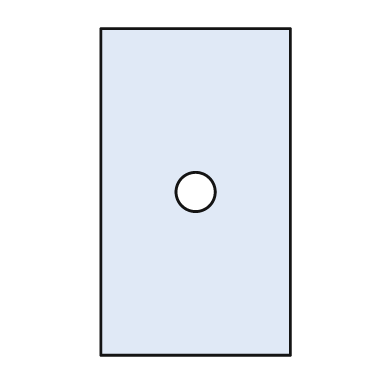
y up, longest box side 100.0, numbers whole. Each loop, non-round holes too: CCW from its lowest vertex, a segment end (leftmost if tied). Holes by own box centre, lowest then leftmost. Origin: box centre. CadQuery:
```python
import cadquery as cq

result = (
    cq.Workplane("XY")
    .moveTo(-29.0, -50.0)
    .lineTo(29.0, -50.0)
    .lineTo(29.0, 50.0)
    .lineTo(-29.0, 50.0)
    .close()
    .moveTo(0.0, 0.0)
    .circle(6.0)
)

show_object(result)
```